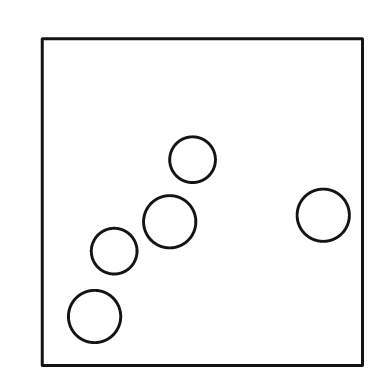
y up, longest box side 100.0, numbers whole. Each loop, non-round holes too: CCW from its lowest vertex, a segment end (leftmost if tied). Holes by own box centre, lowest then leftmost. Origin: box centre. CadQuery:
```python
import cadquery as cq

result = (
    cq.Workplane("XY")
    .moveTo(-49.0, -50.0)
    .lineTo(49.0, -50.0)
    .lineTo(49.0, 50.0)
    .lineTo(-49.0, 50.0)
    .close()
    .moveTo(-33.0, -35.0)
    .circle(8.0)
    .moveTo(-27.0, -15.0)
    .circle(7.0)
    .moveTo(-10.0, -6.0)
    .circle(8.0)
    .moveTo(37.0, -4.0)
    .circle(8.0)
    .moveTo(-3.0, 13.0)
    .circle(7.0)
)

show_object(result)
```